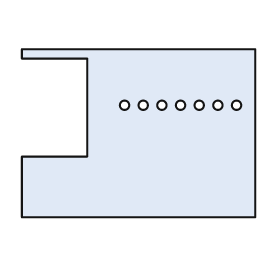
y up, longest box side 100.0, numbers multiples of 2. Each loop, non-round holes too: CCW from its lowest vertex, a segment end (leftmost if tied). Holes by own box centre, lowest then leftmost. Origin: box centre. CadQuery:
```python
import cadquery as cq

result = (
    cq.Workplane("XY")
    .moveTo(-50.0, -36.0)
    .lineTo(50.0, -36.0)
    .lineTo(50.0, 36.0)
    .lineTo(-50.0, 36.0)
    .lineTo(-50.0, 32.0)
    .lineTo(-22.0, 32.0)
    .lineTo(-22.0, -10.0)
    .lineTo(-50.0, -10.0)
    .close()
    .moveTo(-6.0, 12.0)
    .circle(2.0)
    .moveTo(2.0, 12.0)
    .circle(2.0)
    .moveTo(10.0, 12.0)
    .circle(2.0)
    .moveTo(18.0, 12.0)
    .circle(2.0)
    .moveTo(26.0, 12.0)
    .circle(2.0)
    .moveTo(34.0, 12.0)
    .circle(2.0)
    .moveTo(42.0, 12.0)
    .circle(2.0)
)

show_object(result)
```